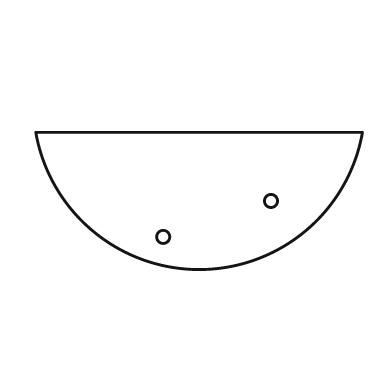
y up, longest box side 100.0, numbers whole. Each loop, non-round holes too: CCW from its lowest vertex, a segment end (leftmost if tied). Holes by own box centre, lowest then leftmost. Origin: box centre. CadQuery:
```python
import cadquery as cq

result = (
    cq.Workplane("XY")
    .moveTo(-50.0, 21.0)
    .threePointArc((0.0, -21.0), (50.0, 21.0))
    .close()
    .moveTo(-11.0, -11.0)
    .circle(2.0)
    .moveTo(22.0, 0.0)
    .circle(2.0)
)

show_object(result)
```